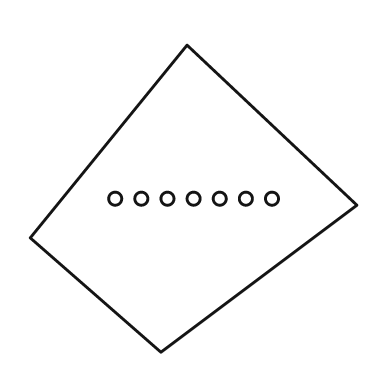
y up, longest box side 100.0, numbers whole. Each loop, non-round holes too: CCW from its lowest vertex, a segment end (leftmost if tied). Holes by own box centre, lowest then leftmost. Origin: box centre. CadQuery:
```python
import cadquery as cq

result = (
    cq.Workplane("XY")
    .moveTo(-10.0, -47.0)
    .lineTo(50.0, -2.0)
    .lineTo(-2.0, 47.0)
    .lineTo(-50.0, -12.0)
    .close()
    .moveTo(-24.0, 0.0)
    .circle(2.0)
    .moveTo(-16.0, 0.0)
    .circle(2.0)
    .moveTo(-8.0, 0.0)
    .circle(2.0)
    .moveTo(0.0, 0.0)
    .circle(2.0)
    .moveTo(8.0, 0.0)
    .circle(2.0)
    .moveTo(16.0, 0.0)
    .circle(2.0)
    .moveTo(24.0, 0.0)
    .circle(2.0)
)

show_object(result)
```